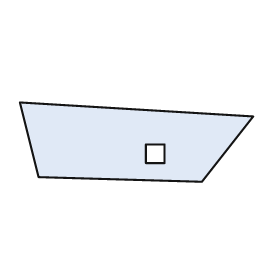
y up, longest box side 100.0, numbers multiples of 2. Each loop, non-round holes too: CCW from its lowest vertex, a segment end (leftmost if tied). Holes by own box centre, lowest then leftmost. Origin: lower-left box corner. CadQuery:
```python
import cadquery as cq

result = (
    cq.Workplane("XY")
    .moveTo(78.0, 0.0)
    .lineTo(100.0, 28.0)
    .lineTo(0.0, 34.0)
    .lineTo(8.0, 2.0)
    .close()
    .moveTo(54.0, 8.0)
    .lineTo(62.0, 8.0)
    .lineTo(62.0, 16.0)
    .lineTo(54.0, 16.0)
    .close()
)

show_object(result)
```